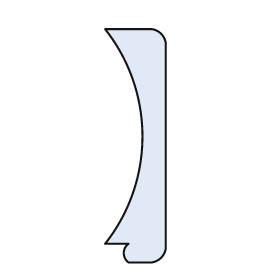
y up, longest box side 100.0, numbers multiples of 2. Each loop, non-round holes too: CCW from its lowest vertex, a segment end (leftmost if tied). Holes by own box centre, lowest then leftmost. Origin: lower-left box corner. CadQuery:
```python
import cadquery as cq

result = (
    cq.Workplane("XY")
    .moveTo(10.0, 0.0)
    .lineTo(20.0, 0.0)
    .threePointArc((24.0, 2.0), (26.0, 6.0))
    .lineTo(26.0, 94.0)
    .threePointArc((24.0, 98.0), (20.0, 100.0))
    .lineTo(0.0, 100.0)
    .threePointArc((16.0, 54.0), (0.0, 8.0))
    .lineTo(10.0, 8.0)
    .threePointArc((8.0, 4.0), (10.0, 0.0))
    .close()
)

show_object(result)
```